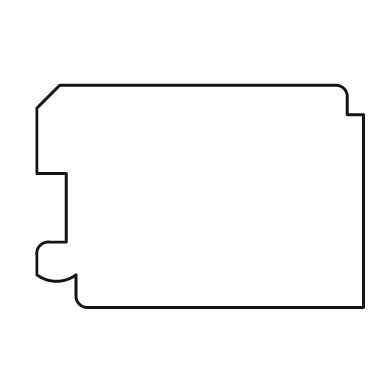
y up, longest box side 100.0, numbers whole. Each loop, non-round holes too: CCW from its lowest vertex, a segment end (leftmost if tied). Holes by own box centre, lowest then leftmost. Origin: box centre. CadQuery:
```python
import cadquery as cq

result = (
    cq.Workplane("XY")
    .moveTo(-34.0, -34.0)
    .lineTo(50.0, -34.0)
    .lineTo(50.0, 25.0)
    .lineTo(45.0, 25.0)
    .lineTo(45.0, 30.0)
    .threePointArc((44.0, 33.0), (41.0, 34.0))
    .lineTo(-43.0, 34.0)
    .lineTo(-50.0, 27.0)
    .lineTo(-50.0, 7.0)
    .lineTo(-41.0, 7.0)
    .lineTo(-41.0, -14.0)
    .lineTo(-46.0, -14.0)
    .threePointArc((-49.0, -15.0), (-50.0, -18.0))
    .lineTo(-50.0, -24.0)
    .threePointArc((-44.0, -26.0), (-38.0, -24.0))
    .lineTo(-38.0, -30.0)
    .threePointArc((-37.0, -33.0), (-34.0, -34.0))
    .close()
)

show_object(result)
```